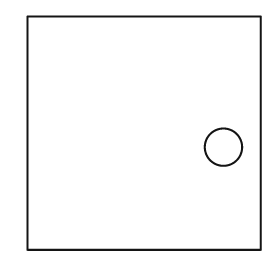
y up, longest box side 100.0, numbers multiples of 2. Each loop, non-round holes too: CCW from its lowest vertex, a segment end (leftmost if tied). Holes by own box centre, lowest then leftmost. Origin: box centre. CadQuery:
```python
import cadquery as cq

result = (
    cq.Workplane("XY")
    .moveTo(-50.0, -50.0)
    .lineTo(50.0, -50.0)
    .lineTo(50.0, 50.0)
    .lineTo(-50.0, 50.0)
    .close()
    .moveTo(34.0, -6.0)
    .circle(8.0)
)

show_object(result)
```